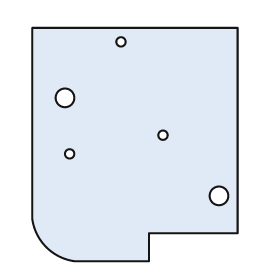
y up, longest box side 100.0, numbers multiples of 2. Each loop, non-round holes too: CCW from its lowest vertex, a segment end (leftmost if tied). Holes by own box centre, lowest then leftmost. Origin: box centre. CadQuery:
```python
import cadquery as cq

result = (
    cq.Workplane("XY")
    .moveTo(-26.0, -50.0)
    .lineTo(6.0, -50.0)
    .lineTo(6.0, -38.0)
    .lineTo(44.0, -38.0)
    .lineTo(44.0, 50.0)
    .lineTo(-44.0, 50.0)
    .lineTo(-44.0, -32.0)
    .threePointArc((-38.0, -44.0), (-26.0, -50.0))
    .close()
    .moveTo(36.0, -22.0)
    .circle(4.0)
    .moveTo(-28.0, -4.0)
    .circle(2.0)
    .moveTo(12.0, 4.0)
    .circle(2.0)
    .moveTo(-30.0, 20.0)
    .circle(4.0)
    .moveTo(-6.0, 44.0)
    .circle(2.0)
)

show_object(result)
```